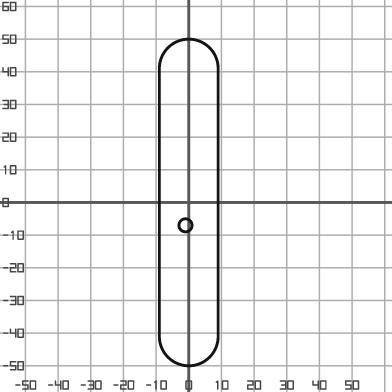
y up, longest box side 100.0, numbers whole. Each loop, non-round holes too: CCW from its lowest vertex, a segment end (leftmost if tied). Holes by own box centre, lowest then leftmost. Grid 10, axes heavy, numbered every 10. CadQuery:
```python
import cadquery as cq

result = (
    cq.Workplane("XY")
    .moveTo(-9.0, -41.0)
    .threePointArc((0.0, -50.0), (9.0, -41.0))
    .lineTo(9.0, 41.0)
    .threePointArc((0.0, 50.0), (-9.0, 41.0))
    .close()
    .moveTo(-1.0, -7.0)
    .circle(2.0)
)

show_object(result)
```